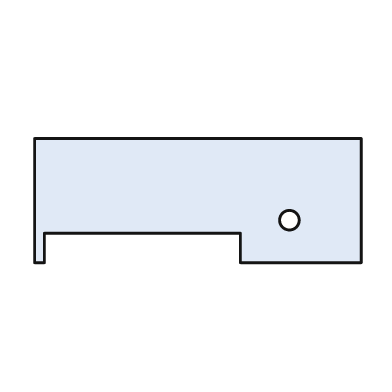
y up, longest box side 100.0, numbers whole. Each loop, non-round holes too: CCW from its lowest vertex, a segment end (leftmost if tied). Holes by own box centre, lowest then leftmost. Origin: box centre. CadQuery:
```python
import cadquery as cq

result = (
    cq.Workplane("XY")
    .moveTo(-50.0, -19.0)
    .lineTo(-47.0, -19.0)
    .lineTo(-47.0, -10.0)
    .lineTo(13.0, -10.0)
    .lineTo(13.0, -19.0)
    .lineTo(50.0, -19.0)
    .lineTo(50.0, 19.0)
    .lineTo(-50.0, 19.0)
    .close()
    .moveTo(28.0, -6.0)
    .circle(3.0)
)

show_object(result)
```